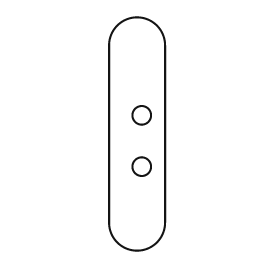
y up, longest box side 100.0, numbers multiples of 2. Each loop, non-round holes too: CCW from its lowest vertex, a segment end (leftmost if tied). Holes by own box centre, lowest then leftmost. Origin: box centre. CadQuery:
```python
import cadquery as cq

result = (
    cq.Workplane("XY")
    .moveTo(-12.0, -38.0)
    .threePointArc((0.0, -50.0), (12.0, -38.0))
    .lineTo(12.0, 38.0)
    .threePointArc((0.0, 50.0), (-12.0, 38.0))
    .close()
    .moveTo(2.0, -14.0)
    .circle(4.0)
    .moveTo(2.0, 8.0)
    .circle(4.0)
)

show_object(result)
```